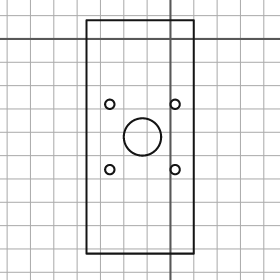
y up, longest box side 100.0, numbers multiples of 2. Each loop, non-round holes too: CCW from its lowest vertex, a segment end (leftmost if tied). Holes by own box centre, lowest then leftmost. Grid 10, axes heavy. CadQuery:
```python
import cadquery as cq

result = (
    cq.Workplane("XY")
    .moveTo(-36.0, -92.0)
    .lineTo(10.0, -92.0)
    .lineTo(10.0, 8.0)
    .lineTo(-36.0, 8.0)
    .close()
    .moveTo(-26.0, -56.0)
    .circle(2.0)
    .moveTo(2.0, -56.0)
    .circle(2.0)
    .moveTo(-12.0, -42.0)
    .circle(8.0)
    .moveTo(-26.0, -28.0)
    .circle(2.0)
    .moveTo(2.0, -28.0)
    .circle(2.0)
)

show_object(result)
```